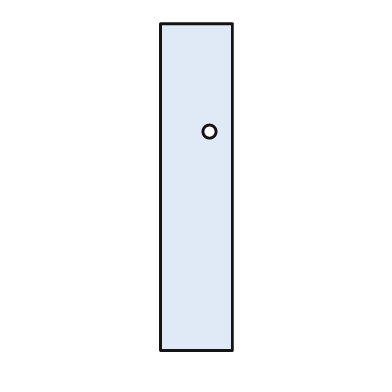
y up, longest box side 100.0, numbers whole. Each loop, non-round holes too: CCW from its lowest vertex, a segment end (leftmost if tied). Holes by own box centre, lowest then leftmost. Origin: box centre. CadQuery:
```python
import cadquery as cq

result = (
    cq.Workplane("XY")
    .moveTo(-11.0, -50.0)
    .lineTo(11.0, -50.0)
    .lineTo(11.0, 50.0)
    .lineTo(-11.0, 50.0)
    .close()
    .moveTo(4.0, 17.0)
    .circle(2.0)
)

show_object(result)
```